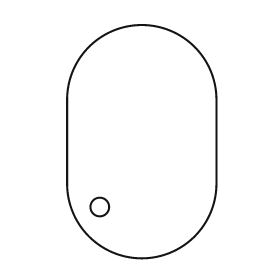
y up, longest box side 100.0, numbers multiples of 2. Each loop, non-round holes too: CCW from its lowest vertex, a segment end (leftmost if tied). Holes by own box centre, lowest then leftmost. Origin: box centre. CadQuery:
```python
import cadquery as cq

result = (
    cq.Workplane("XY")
    .moveTo(-32.0, -18.0)
    .threePointArc((0.0, -50.0), (32.0, -18.0))
    .lineTo(32.0, 18.0)
    .threePointArc((0.0, 50.0), (-32.0, 18.0))
    .close()
    .moveTo(-18.0, -28.0)
    .circle(4.0)
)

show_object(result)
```